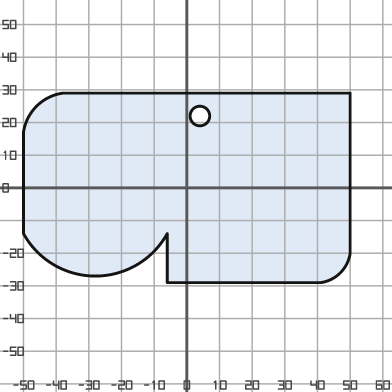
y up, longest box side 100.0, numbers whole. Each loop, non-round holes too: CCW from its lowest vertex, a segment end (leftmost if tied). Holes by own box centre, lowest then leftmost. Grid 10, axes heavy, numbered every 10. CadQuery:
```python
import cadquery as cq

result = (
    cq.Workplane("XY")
    .moveTo(-6.0, -29.0)
    .lineTo(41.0, -29.0)
    .threePointArc((47.0, -26.0), (50.0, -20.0))
    .lineTo(50.0, 29.0)
    .lineTo(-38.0, 29.0)
    .threePointArc((-46.0, 25.0), (-50.0, 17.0))
    .lineTo(-50.0, -14.0)
    .threePointArc((-28.0, -27.0), (-6.0, -14.0))
    .close()
    .moveTo(4.0, 22.0)
    .circle(3.0)
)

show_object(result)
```